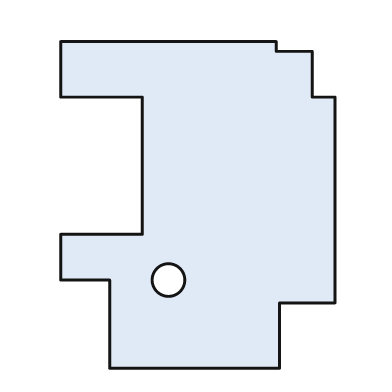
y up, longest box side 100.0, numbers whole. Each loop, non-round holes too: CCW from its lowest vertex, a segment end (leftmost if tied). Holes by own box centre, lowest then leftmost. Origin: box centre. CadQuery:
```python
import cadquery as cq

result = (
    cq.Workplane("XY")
    .moveTo(-27.0, -50.0)
    .lineTo(25.0, -50.0)
    .lineTo(25.0, -30.0)
    .lineTo(42.0, -30.0)
    .lineTo(42.0, 33.0)
    .lineTo(35.0, 33.0)
    .lineTo(35.0, 47.0)
    .lineTo(24.0, 47.0)
    .lineTo(24.0, 50.0)
    .lineTo(-42.0, 50.0)
    .lineTo(-42.0, 33.0)
    .lineTo(-17.0, 33.0)
    .lineTo(-17.0, -9.0)
    .lineTo(-42.0, -9.0)
    .lineTo(-42.0, -23.0)
    .lineTo(-27.0, -23.0)
    .close()
    .moveTo(-9.0, -23.0)
    .circle(5.0)
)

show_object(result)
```